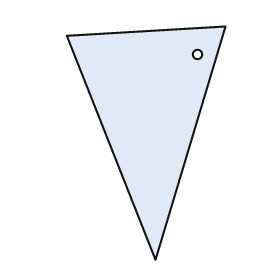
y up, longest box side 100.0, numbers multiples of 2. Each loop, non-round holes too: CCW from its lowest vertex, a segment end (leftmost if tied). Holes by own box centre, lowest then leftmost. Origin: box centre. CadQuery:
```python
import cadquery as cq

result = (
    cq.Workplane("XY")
    .moveTo(4.0, -50.0)
    .lineTo(34.0, 50.0)
    .lineTo(-34.0, 46.0)
    .close()
    .moveTo(22.0, 38.0)
    .circle(2.0)
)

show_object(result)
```